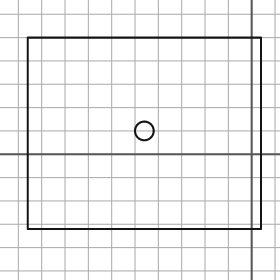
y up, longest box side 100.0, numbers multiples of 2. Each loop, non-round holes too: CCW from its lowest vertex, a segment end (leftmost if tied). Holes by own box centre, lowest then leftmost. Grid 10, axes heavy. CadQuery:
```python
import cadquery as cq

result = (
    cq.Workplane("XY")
    .moveTo(-96.0, -32.0)
    .lineTo(4.0, -32.0)
    .lineTo(4.0, 50.0)
    .lineTo(-96.0, 50.0)
    .close()
    .moveTo(-46.0, 10.0)
    .circle(4.0)
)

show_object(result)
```